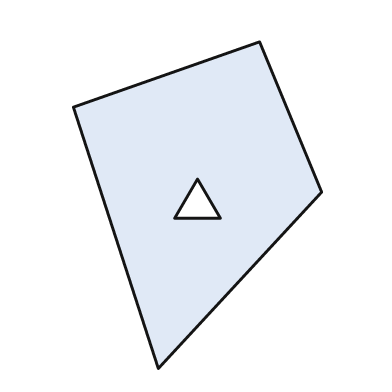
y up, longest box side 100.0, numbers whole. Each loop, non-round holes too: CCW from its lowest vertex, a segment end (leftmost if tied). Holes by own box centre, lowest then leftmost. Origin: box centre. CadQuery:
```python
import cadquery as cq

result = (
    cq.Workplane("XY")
    .moveTo(-12.0, -50.0)
    .lineTo(38.0, 4.0)
    .lineTo(19.0, 50.0)
    .lineTo(-38.0, 30.0)
    .close()
    .moveTo(-7.0, -4.0)
    .lineTo(7.0, -4.0)
    .lineTo(0.0, 8.0)
    .close()
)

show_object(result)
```